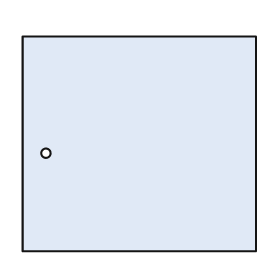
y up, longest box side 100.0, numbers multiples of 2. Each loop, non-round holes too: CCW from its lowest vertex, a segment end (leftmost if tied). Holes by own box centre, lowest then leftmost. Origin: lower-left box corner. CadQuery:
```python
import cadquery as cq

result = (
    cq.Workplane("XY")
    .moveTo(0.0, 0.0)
    .lineTo(100.0, 0.0)
    .lineTo(100.0, 92.0)
    .lineTo(0.0, 92.0)
    .close()
    .moveTo(10.0, 42.0)
    .circle(2.0)
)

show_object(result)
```